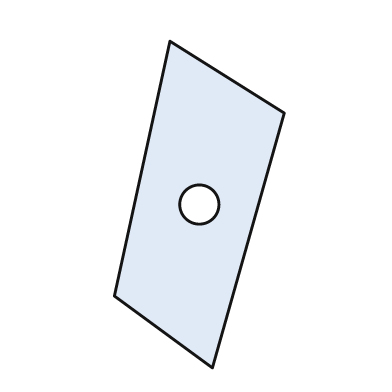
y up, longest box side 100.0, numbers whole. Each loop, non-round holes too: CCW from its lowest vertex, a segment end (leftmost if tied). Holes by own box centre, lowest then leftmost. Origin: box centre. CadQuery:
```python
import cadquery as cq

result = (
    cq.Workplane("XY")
    .moveTo(4.0, -50.0)
    .lineTo(26.0, 28.0)
    .lineTo(-9.0, 50.0)
    .lineTo(-26.0, -28.0)
    .close()
    .moveTo(0.0, 0.0)
    .circle(6.0)
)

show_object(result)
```